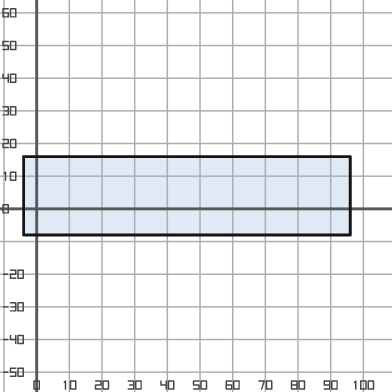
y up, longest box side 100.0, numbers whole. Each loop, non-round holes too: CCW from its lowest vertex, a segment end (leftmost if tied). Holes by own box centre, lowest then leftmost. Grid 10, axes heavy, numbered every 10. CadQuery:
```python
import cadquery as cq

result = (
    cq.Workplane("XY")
    .moveTo(-4.0, -8.0)
    .lineTo(96.0, -8.0)
    .lineTo(96.0, 16.0)
    .lineTo(-4.0, 16.0)
    .close()
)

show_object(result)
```